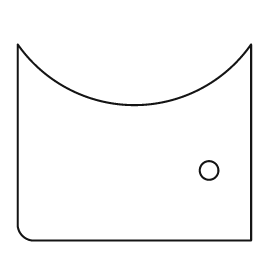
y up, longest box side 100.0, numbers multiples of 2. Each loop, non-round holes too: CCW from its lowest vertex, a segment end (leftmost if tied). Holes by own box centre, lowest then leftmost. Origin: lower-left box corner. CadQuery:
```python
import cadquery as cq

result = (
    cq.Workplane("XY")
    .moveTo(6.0, 0.0)
    .lineTo(100.0, 0.0)
    .lineTo(100.0, 84.0)
    .threePointArc((50.0, 58.0), (0.0, 84.0))
    .lineTo(0.0, 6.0)
    .threePointArc((2.0, 2.0), (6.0, 0.0))
    .close()
    .moveTo(82.0, 30.0)
    .circle(4.0)
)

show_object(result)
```